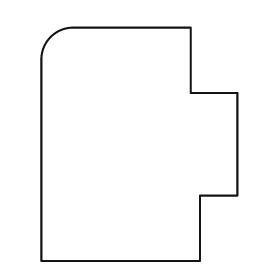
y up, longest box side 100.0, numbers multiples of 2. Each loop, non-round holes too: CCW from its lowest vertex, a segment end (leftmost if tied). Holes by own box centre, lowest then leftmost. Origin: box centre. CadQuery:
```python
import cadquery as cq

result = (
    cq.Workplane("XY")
    .moveTo(-42.0, -50.0)
    .lineTo(26.0, -50.0)
    .lineTo(26.0, -22.0)
    .lineTo(42.0, -22.0)
    .lineTo(42.0, 22.0)
    .lineTo(22.0, 22.0)
    .lineTo(22.0, 50.0)
    .lineTo(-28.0, 50.0)
    .threePointArc((-38.0, 46.0), (-42.0, 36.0))
    .close()
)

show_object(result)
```